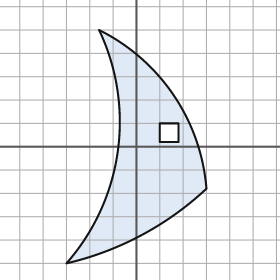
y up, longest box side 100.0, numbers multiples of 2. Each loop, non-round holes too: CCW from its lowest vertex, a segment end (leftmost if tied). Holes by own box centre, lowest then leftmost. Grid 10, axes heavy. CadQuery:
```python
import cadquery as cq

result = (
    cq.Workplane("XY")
    .moveTo(-30.0, -50.0)
    .threePointArc((2.0, -38.0), (30.0, -18.0))
    .threePointArc((16.0, 22.0), (-16.0, 50.0))
    .threePointArc((-8.0, -2.0), (-30.0, -50.0))
    .close()
    .moveTo(10.0, 2.0)
    .lineTo(18.0, 2.0)
    .lineTo(18.0, 10.0)
    .lineTo(10.0, 10.0)
    .close()
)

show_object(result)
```